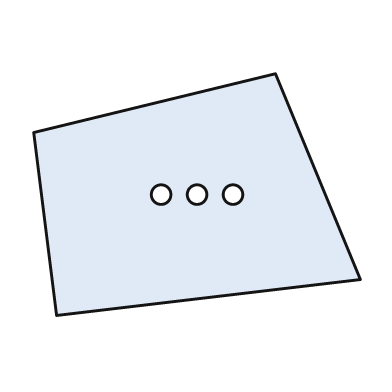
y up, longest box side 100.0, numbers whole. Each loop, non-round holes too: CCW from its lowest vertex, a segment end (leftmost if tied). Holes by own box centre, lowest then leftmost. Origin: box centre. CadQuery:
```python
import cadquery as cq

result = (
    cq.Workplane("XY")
    .moveTo(-43.0, -37.0)
    .lineTo(50.0, -26.0)
    .lineTo(24.0, 37.0)
    .lineTo(-50.0, 19.0)
    .close()
    .moveTo(-11.0, 0.0)
    .circle(3.0)
    .moveTo(0.0, 0.0)
    .circle(3.0)
    .moveTo(11.0, 0.0)
    .circle(3.0)
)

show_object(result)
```